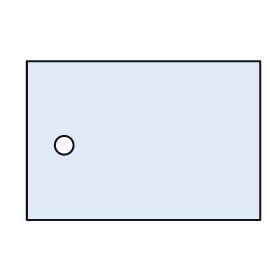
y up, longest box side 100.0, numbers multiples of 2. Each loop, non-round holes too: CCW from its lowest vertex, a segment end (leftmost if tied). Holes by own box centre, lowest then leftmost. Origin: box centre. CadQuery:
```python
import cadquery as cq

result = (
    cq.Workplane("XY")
    .moveTo(-50.0, -34.0)
    .lineTo(50.0, -34.0)
    .lineTo(50.0, 34.0)
    .lineTo(-50.0, 34.0)
    .close()
    .moveTo(-34.0, -2.0)
    .circle(4.0)
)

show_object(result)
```